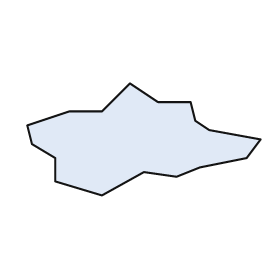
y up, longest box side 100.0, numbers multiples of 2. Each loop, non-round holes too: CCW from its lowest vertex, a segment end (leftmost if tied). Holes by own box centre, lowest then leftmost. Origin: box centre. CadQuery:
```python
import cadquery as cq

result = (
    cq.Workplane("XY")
    .moveTo(-18.0, -24.0)
    .lineTo(0.0, -14.0)
    .lineTo(14.0, -16.0)
    .lineTo(24.0, -12.0)
    .lineTo(44.0, -8.0)
    .lineTo(50.0, 0.0)
    .lineTo(28.0, 4.0)
    .lineTo(22.0, 8.0)
    .lineTo(20.0, 16.0)
    .lineTo(6.0, 16.0)
    .lineTo(-6.0, 24.0)
    .lineTo(-18.0, 12.0)
    .lineTo(-32.0, 12.0)
    .lineTo(-50.0, 6.0)
    .lineTo(-48.0, -2.0)
    .lineTo(-38.0, -8.0)
    .lineTo(-38.0, -18.0)
    .close()
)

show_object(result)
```